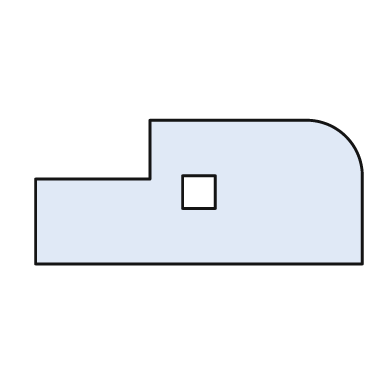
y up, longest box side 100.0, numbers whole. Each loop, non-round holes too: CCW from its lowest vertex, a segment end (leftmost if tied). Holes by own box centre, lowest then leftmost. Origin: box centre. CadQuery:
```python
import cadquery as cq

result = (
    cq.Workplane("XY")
    .moveTo(-50.0, -22.0)
    .lineTo(50.0, -22.0)
    .lineTo(50.0, 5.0)
    .threePointArc((45.0, 17.0), (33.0, 22.0))
    .lineTo(-15.0, 22.0)
    .lineTo(-15.0, 4.0)
    .lineTo(-50.0, 4.0)
    .close()
    .moveTo(-5.0, -5.0)
    .lineTo(5.0, -5.0)
    .lineTo(5.0, 5.0)
    .lineTo(-5.0, 5.0)
    .close()
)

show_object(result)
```